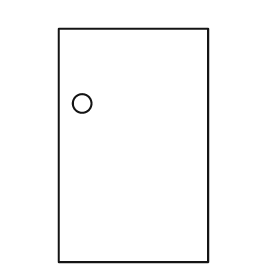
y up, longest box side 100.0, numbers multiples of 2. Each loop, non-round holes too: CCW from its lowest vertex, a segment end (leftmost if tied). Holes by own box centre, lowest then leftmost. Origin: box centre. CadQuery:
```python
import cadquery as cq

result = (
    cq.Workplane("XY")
    .moveTo(-32.0, -50.0)
    .lineTo(32.0, -50.0)
    .lineTo(32.0, 50.0)
    .lineTo(-32.0, 50.0)
    .close()
    .moveTo(-22.0, 18.0)
    .circle(4.0)
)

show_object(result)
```